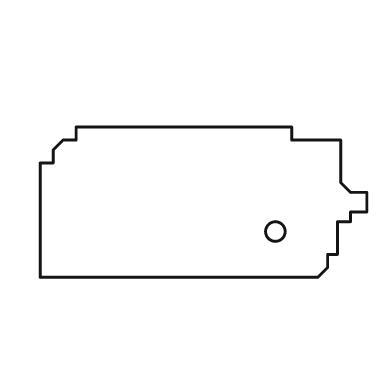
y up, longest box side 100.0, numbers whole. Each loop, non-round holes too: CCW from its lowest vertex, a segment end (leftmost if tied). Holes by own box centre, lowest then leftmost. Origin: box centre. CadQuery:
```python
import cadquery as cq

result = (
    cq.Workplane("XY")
    .moveTo(-50.0, -23.0)
    .lineTo(35.0, -23.0)
    .lineTo(38.0, -20.0)
    .lineTo(38.0, -16.0)
    .lineTo(41.0, -16.0)
    .lineTo(41.0, -6.0)
    .lineTo(45.0, -6.0)
    .lineTo(45.0, -3.0)
    .lineTo(50.0, -3.0)
    .lineTo(50.0, 3.0)
    .lineTo(45.0, 3.0)
    .lineTo(42.0, 6.0)
    .lineTo(42.0, 19.0)
    .lineTo(27.0, 19.0)
    .lineTo(27.0, 23.0)
    .lineTo(-39.0, 23.0)
    .lineTo(-39.0, 19.0)
    .lineTo(-43.0, 19.0)
    .lineTo(-46.0, 16.0)
    .lineTo(-46.0, 12.0)
    .lineTo(-50.0, 12.0)
    .close()
    .moveTo(22.0, -9.0)
    .circle(3.0)
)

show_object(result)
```